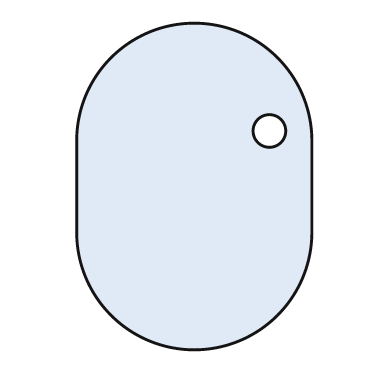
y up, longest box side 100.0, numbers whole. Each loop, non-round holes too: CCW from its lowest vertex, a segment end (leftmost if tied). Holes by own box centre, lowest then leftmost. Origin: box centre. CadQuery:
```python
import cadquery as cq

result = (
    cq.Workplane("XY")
    .moveTo(-36.0, -14.0)
    .threePointArc((0.0, -50.0), (36.0, -14.0))
    .lineTo(36.0, 14.0)
    .threePointArc((0.0, 50.0), (-36.0, 14.0))
    .close()
    .moveTo(23.0, 17.0)
    .circle(5.0)
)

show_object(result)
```